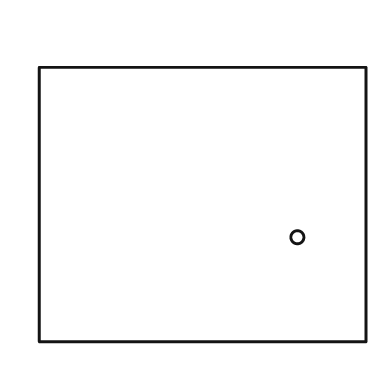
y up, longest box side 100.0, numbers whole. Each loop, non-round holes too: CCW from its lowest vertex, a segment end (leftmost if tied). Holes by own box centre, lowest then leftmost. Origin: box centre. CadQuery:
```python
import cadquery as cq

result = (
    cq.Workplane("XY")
    .moveTo(-50.0, -42.0)
    .lineTo(50.0, -42.0)
    .lineTo(50.0, 42.0)
    .lineTo(-50.0, 42.0)
    .close()
    .moveTo(29.0, -10.0)
    .circle(2.0)
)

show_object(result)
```